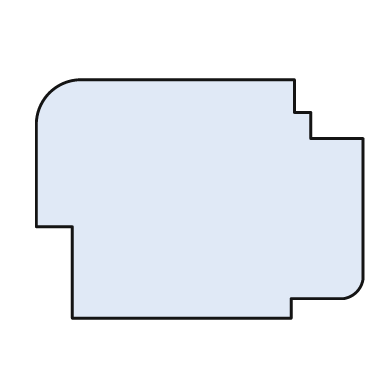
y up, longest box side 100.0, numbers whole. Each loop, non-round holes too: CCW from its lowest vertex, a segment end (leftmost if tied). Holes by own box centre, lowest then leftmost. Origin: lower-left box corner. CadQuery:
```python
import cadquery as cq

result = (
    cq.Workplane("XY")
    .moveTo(11.0, 0.0)
    .lineTo(78.0, 0.0)
    .lineTo(78.0, 6.0)
    .lineTo(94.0, 6.0)
    .threePointArc((98.0, 8.0), (100.0, 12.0))
    .lineTo(100.0, 55.0)
    .lineTo(84.0, 55.0)
    .lineTo(84.0, 63.0)
    .lineTo(79.0, 63.0)
    .lineTo(79.0, 73.0)
    .lineTo(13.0, 73.0)
    .threePointArc((4.0, 69.0), (0.0, 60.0))
    .lineTo(0.0, 28.0)
    .lineTo(11.0, 28.0)
    .close()
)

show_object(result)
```